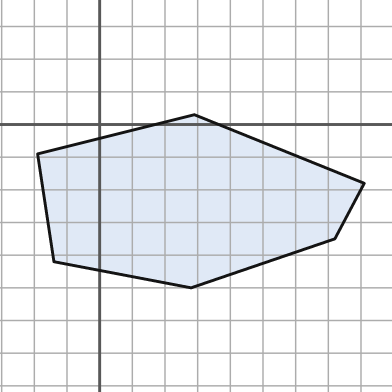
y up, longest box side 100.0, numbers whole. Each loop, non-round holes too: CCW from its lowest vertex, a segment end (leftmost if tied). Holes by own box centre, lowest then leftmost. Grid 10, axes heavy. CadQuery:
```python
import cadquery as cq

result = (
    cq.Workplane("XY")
    .moveTo(28.0, -50.0)
    .lineTo(72.0, -35.0)
    .lineTo(81.0, -18.0)
    .lineTo(29.0, 3.0)
    .lineTo(-19.0, -9.0)
    .lineTo(-14.0, -42.0)
    .close()
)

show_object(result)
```